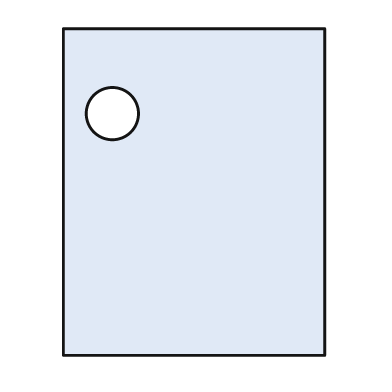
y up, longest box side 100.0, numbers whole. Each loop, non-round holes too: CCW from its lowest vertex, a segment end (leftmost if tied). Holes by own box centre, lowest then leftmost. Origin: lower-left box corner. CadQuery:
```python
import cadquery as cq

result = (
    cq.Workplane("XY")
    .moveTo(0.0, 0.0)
    .lineTo(80.0, 0.0)
    .lineTo(80.0, 100.0)
    .lineTo(0.0, 100.0)
    .close()
    .moveTo(15.0, 74.0)
    .circle(8.0)
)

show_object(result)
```